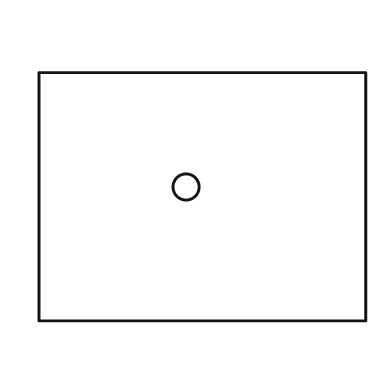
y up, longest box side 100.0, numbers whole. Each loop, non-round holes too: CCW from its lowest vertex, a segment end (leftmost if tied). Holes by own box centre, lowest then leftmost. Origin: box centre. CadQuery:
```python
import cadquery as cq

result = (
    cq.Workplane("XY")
    .moveTo(-50.0, -38.0)
    .lineTo(50.0, -38.0)
    .lineTo(50.0, 38.0)
    .lineTo(-50.0, 38.0)
    .close()
    .moveTo(-5.0, 3.0)
    .circle(4.0)
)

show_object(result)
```